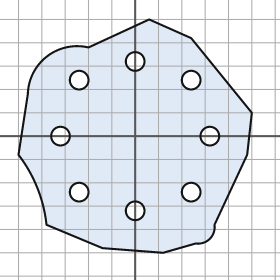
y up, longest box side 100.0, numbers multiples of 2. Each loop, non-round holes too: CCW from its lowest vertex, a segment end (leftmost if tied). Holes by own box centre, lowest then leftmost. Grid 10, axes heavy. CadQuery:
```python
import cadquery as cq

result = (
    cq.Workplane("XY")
    .moveTo(12.0, -50.0)
    .lineTo(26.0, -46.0)
    .threePointArc((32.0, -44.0), (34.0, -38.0))
    .lineTo(48.0, -8.0)
    .lineTo(50.0, 10.0)
    .lineTo(24.0, 42.0)
    .lineTo(6.0, 50.0)
    .lineTo(-20.0, 38.0)
    .threePointArc((-38.0, 34.0), (-46.0, 18.0))
    .lineTo(-50.0, -8.0)
    .threePointArc((-42.0, -22.0), (-38.0, -38.0))
    .lineTo(-14.0, -48.0)
    .close()
    .moveTo(0.0, -32.0)
    .circle(4.0)
    .moveTo(-24.0, -24.0)
    .circle(4.0)
    .moveTo(24.0, -24.0)
    .circle(4.0)
    .moveTo(-32.0, 0.0)
    .circle(4.0)
    .moveTo(32.0, 0.0)
    .circle(4.0)
    .moveTo(-24.0, 24.0)
    .circle(4.0)
    .moveTo(24.0, 24.0)
    .circle(4.0)
    .moveTo(0.0, 32.0)
    .circle(4.0)
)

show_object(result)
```